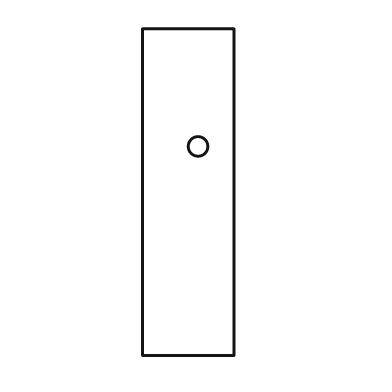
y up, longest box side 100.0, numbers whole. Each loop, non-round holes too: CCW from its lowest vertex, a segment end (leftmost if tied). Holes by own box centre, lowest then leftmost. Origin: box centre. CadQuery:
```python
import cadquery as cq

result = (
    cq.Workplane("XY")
    .moveTo(-14.0, -50.0)
    .lineTo(14.0, -50.0)
    .lineTo(14.0, 50.0)
    .lineTo(-14.0, 50.0)
    .close()
    .moveTo(3.0, 14.0)
    .circle(3.0)
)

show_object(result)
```